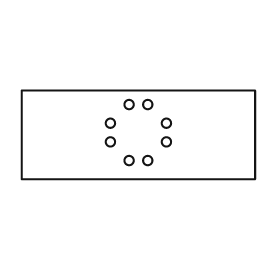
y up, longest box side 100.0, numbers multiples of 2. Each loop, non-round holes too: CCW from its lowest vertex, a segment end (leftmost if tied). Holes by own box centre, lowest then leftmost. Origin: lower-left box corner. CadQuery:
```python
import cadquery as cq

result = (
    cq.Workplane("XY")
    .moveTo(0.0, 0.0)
    .lineTo(100.0, 0.0)
    .lineTo(100.0, 38.0)
    .lineTo(0.0, 38.0)
    .close()
    .moveTo(46.0, 8.0)
    .circle(2.0)
    .moveTo(54.0, 8.0)
    .circle(2.0)
    .moveTo(38.0, 16.0)
    .circle(2.0)
    .moveTo(62.0, 16.0)
    .circle(2.0)
    .moveTo(38.0, 24.0)
    .circle(2.0)
    .moveTo(62.0, 24.0)
    .circle(2.0)
    .moveTo(46.0, 32.0)
    .circle(2.0)
    .moveTo(54.0, 32.0)
    .circle(2.0)
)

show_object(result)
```